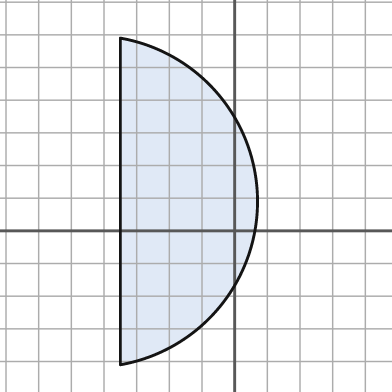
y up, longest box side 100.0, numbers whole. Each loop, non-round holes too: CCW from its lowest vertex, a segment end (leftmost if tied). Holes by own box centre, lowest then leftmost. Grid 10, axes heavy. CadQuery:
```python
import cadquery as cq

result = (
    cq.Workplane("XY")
    .moveTo(-35.0, -41.0)
    .threePointArc((7.0, 9.0), (-35.0, 59.0))
    .close()
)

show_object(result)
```